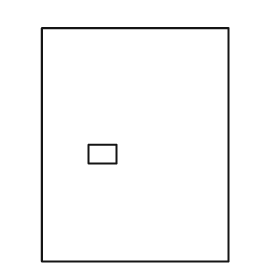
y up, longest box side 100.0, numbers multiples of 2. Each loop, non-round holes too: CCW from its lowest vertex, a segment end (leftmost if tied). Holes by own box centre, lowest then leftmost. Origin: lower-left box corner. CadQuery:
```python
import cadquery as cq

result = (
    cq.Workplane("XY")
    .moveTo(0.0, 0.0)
    .lineTo(80.0, 0.0)
    .lineTo(80.0, 100.0)
    .lineTo(0.0, 100.0)
    .close()
    .moveTo(20.0, 42.0)
    .lineTo(32.0, 42.0)
    .lineTo(32.0, 50.0)
    .lineTo(20.0, 50.0)
    .close()
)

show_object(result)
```